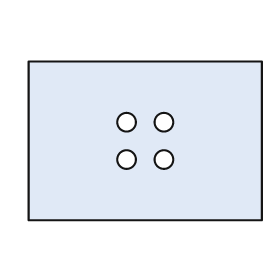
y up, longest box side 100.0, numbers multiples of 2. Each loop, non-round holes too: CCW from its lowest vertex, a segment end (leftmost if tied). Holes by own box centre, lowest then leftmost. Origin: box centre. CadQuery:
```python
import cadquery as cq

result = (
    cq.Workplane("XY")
    .moveTo(-50.0, -34.0)
    .lineTo(50.0, -34.0)
    .lineTo(50.0, 34.0)
    .lineTo(-50.0, 34.0)
    .close()
    .moveTo(-8.0, -8.0)
    .circle(4.0)
    .moveTo(8.0, -8.0)
    .circle(4.0)
    .moveTo(-8.0, 8.0)
    .circle(4.0)
    .moveTo(8.0, 8.0)
    .circle(4.0)
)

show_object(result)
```